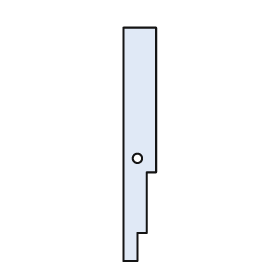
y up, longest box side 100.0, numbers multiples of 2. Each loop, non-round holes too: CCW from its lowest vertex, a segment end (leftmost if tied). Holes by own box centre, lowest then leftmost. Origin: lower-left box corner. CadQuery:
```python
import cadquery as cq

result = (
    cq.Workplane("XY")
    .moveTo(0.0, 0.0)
    .lineTo(6.0, 0.0)
    .lineTo(6.0, 12.0)
    .lineTo(10.0, 12.0)
    .lineTo(10.0, 38.0)
    .lineTo(14.0, 38.0)
    .lineTo(14.0, 100.0)
    .lineTo(0.0, 100.0)
    .close()
    .moveTo(6.0, 44.0)
    .circle(2.0)
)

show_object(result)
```